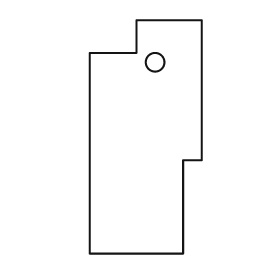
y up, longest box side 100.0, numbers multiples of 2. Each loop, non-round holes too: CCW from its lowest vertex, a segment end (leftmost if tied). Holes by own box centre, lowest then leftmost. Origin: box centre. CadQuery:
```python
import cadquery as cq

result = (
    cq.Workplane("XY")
    .moveTo(-24.0, -50.0)
    .lineTo(16.0, -50.0)
    .lineTo(16.0, -10.0)
    .lineTo(24.0, -10.0)
    .lineTo(24.0, 50.0)
    .lineTo(-4.0, 50.0)
    .lineTo(-4.0, 36.0)
    .lineTo(-24.0, 36.0)
    .close()
    .moveTo(4.0, 32.0)
    .circle(4.0)
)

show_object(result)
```